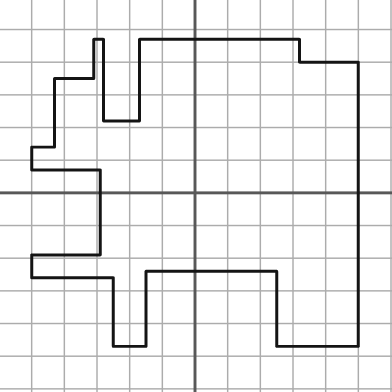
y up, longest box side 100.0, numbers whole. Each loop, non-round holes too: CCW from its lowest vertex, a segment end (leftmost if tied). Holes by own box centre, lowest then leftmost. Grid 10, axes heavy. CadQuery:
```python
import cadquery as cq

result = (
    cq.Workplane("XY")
    .moveTo(-25.0, -47.0)
    .lineTo(-15.0, -47.0)
    .lineTo(-15.0, -24.0)
    .lineTo(25.0, -24.0)
    .lineTo(25.0, -47.0)
    .lineTo(50.0, -47.0)
    .lineTo(50.0, 40.0)
    .lineTo(32.0, 40.0)
    .lineTo(32.0, 47.0)
    .lineTo(-17.0, 47.0)
    .lineTo(-17.0, 22.0)
    .lineTo(-28.0, 22.0)
    .lineTo(-28.0, 47.0)
    .lineTo(-31.0, 47.0)
    .lineTo(-31.0, 35.0)
    .lineTo(-43.0, 35.0)
    .lineTo(-43.0, 14.0)
    .lineTo(-50.0, 14.0)
    .lineTo(-50.0, 7.0)
    .lineTo(-29.0, 7.0)
    .lineTo(-29.0, -19.0)
    .lineTo(-50.0, -19.0)
    .lineTo(-50.0, -26.0)
    .lineTo(-25.0, -26.0)
    .close()
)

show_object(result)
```